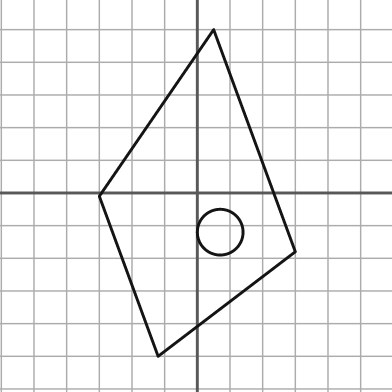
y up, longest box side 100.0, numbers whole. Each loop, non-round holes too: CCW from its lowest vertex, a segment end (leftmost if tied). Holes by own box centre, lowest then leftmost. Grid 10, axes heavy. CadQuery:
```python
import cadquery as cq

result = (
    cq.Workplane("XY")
    .moveTo(-12.0, -50.0)
    .lineTo(30.0, -18.0)
    .lineTo(5.0, 50.0)
    .lineTo(-30.0, -1.0)
    .close()
    .moveTo(7.0, -12.0)
    .circle(7.0)
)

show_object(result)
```